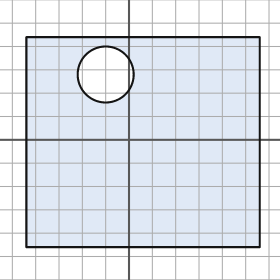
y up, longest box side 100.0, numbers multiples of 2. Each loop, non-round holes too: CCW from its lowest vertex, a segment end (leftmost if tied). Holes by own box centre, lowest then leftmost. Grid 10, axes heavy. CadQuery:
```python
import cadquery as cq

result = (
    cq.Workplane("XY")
    .moveTo(-44.0, -46.0)
    .lineTo(56.0, -46.0)
    .lineTo(56.0, 44.0)
    .lineTo(-44.0, 44.0)
    .close()
    .moveTo(-10.0, 28.0)
    .circle(12.0)
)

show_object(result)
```